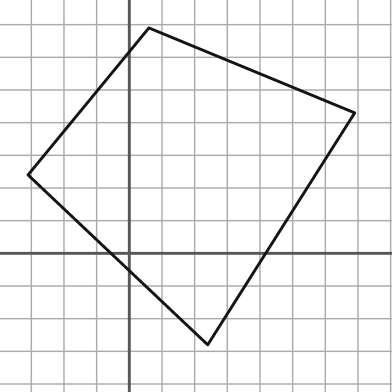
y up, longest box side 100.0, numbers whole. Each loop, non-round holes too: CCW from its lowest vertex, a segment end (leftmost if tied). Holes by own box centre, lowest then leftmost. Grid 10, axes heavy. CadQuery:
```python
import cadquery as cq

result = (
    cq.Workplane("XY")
    .moveTo(24.0, -28.0)
    .lineTo(69.0, 43.0)
    .lineTo(6.0, 69.0)
    .lineTo(-31.0, 24.0)
    .close()
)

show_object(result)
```